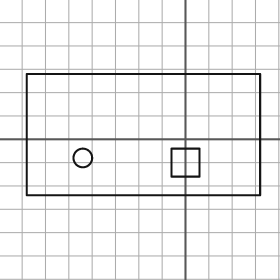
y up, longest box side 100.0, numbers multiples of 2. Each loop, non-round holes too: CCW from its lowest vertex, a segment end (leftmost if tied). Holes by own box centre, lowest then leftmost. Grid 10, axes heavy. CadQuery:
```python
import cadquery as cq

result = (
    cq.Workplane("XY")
    .moveTo(-68.0, -24.0)
    .lineTo(32.0, -24.0)
    .lineTo(32.0, 28.0)
    .lineTo(-68.0, 28.0)
    .close()
    .moveTo(-6.0, -16.0)
    .lineTo(6.0, -16.0)
    .lineTo(6.0, -4.0)
    .lineTo(-6.0, -4.0)
    .close()
    .moveTo(-44.0, -8.0)
    .circle(4.0)
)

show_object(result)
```